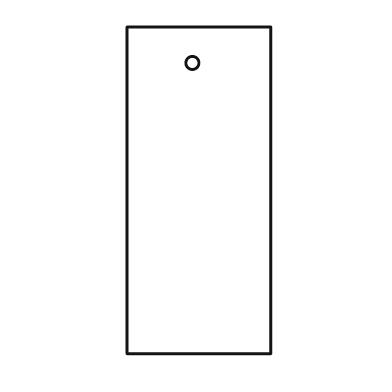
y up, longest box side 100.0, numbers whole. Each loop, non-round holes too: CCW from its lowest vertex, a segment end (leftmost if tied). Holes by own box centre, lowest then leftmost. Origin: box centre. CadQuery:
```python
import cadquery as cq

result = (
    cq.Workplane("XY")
    .moveTo(-22.0, -50.0)
    .lineTo(22.0, -50.0)
    .lineTo(22.0, 50.0)
    .lineTo(-22.0, 50.0)
    .close()
    .moveTo(-2.0, 39.0)
    .circle(2.0)
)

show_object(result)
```